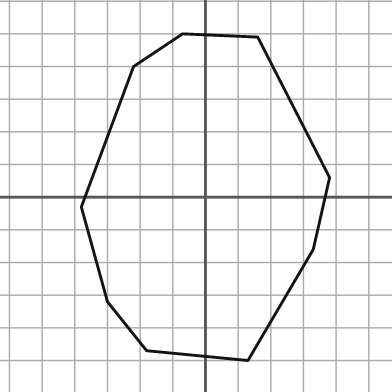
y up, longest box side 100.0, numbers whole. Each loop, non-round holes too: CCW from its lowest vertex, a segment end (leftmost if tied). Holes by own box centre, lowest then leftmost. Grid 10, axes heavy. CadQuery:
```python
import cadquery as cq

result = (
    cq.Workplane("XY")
    .moveTo(13.0, -50.0)
    .lineTo(33.0, -16.0)
    .lineTo(38.0, 6.0)
    .lineTo(16.0, 49.0)
    .lineTo(-7.0, 50.0)
    .lineTo(-22.0, 40.0)
    .lineTo(-38.0, -3.0)
    .lineTo(-30.0, -32.0)
    .lineTo(-18.0, -47.0)
    .close()
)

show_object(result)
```